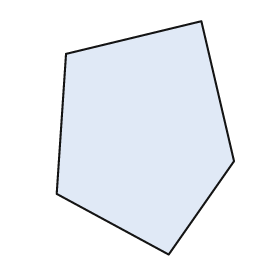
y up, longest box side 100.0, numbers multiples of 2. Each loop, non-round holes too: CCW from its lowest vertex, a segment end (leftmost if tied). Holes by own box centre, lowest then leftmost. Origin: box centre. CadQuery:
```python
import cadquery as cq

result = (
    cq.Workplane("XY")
    .moveTo(10.0, -50.0)
    .lineTo(38.0, -10.0)
    .lineTo(24.0, 50.0)
    .lineTo(-34.0, 36.0)
    .lineTo(-38.0, -24.0)
    .close()
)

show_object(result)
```